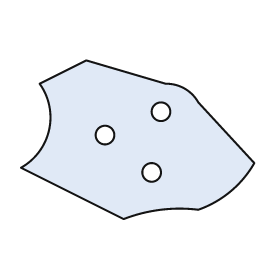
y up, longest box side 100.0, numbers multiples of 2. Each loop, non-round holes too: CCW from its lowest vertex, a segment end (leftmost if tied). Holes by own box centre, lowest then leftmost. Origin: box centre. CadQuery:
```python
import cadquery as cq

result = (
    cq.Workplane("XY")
    .moveTo(-6.0, -34.0)
    .threePointArc((10.0, -30.0), (26.0, -30.0))
    .threePointArc((40.0, -22.0), (50.0, -10.0))
    .lineTo(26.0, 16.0)
    .threePointArc((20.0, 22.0), (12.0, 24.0))
    .lineTo(-22.0, 34.0)
    .lineTo(-42.0, 24.0)
    .threePointArc((-38.0, 4.0), (-50.0, -12.0))
    .close()
    .moveTo(6.0, -14.0)
    .circle(4.0)
    .moveTo(-14.0, 2.0)
    .circle(4.0)
    .moveTo(10.0, 12.0)
    .circle(4.0)
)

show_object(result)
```